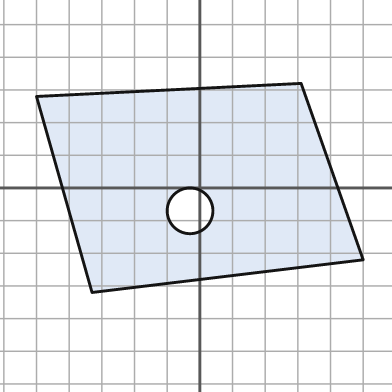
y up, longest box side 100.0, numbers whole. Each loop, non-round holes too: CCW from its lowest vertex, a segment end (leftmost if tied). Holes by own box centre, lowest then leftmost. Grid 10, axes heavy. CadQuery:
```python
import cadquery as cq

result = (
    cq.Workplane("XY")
    .moveTo(-33.0, -32.0)
    .lineTo(50.0, -22.0)
    .lineTo(31.0, 32.0)
    .lineTo(-50.0, 28.0)
    .close()
    .moveTo(-3.0, -7.0)
    .circle(7.0)
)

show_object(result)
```